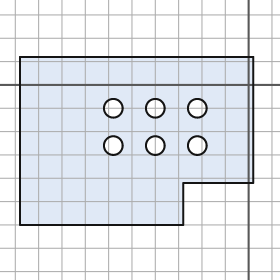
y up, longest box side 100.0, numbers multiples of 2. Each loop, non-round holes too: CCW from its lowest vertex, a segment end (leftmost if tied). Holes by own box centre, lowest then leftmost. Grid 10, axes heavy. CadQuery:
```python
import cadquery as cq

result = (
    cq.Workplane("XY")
    .moveTo(-98.0, -60.0)
    .lineTo(-28.0, -60.0)
    .lineTo(-28.0, -42.0)
    .lineTo(2.0, -42.0)
    .lineTo(2.0, 12.0)
    .lineTo(-98.0, 12.0)
    .close()
    .moveTo(-58.0, -26.0)
    .circle(4.0)
    .moveTo(-40.0, -26.0)
    .circle(4.0)
    .moveTo(-22.0, -26.0)
    .circle(4.0)
    .moveTo(-58.0, -10.0)
    .circle(4.0)
    .moveTo(-40.0, -10.0)
    .circle(4.0)
    .moveTo(-22.0, -10.0)
    .circle(4.0)
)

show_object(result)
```